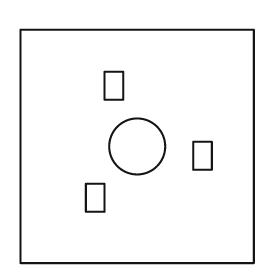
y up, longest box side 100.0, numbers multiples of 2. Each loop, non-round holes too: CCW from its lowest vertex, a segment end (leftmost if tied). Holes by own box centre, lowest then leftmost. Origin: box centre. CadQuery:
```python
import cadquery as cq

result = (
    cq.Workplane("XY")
    .moveTo(-50.0, -50.0)
    .lineTo(50.0, -50.0)
    .lineTo(50.0, 50.0)
    .lineTo(-50.0, 50.0)
    .close()
    .moveTo(-22.0, -28.0)
    .lineTo(-14.0, -28.0)
    .lineTo(-14.0, -16.0)
    .lineTo(-22.0, -16.0)
    .close()
    .moveTo(24.0, -10.0)
    .lineTo(32.0, -10.0)
    .lineTo(32.0, 2.0)
    .lineTo(24.0, 2.0)
    .close()
    .moveTo(0.0, 0.0)
    .circle(12.0)
    .moveTo(-14.0, 20.0)
    .lineTo(-6.0, 20.0)
    .lineTo(-6.0, 32.0)
    .lineTo(-14.0, 32.0)
    .close()
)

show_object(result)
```